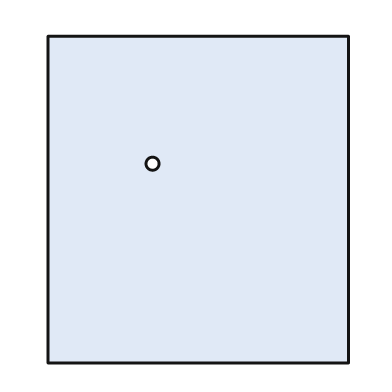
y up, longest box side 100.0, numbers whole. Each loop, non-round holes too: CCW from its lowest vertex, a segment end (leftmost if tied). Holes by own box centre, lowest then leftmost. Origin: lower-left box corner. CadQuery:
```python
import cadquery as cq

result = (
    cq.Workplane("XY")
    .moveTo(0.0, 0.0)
    .lineTo(92.0, 0.0)
    .lineTo(92.0, 100.0)
    .lineTo(0.0, 100.0)
    .close()
    .moveTo(32.0, 61.0)
    .circle(2.0)
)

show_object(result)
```